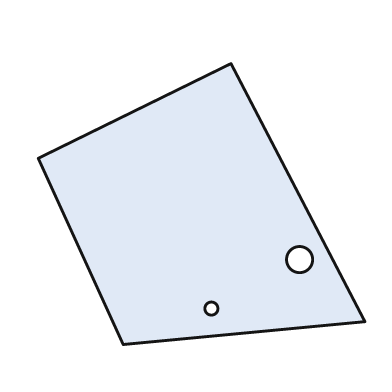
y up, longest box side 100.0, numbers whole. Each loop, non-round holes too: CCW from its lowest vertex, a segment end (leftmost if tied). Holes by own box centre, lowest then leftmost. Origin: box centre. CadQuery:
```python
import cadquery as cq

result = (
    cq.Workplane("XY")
    .moveTo(-24.0, -43.0)
    .lineTo(50.0, -36.0)
    .lineTo(9.0, 43.0)
    .lineTo(-50.0, 14.0)
    .close()
    .moveTo(3.0, -32.0)
    .circle(2.0)
    .moveTo(30.0, -17.0)
    .circle(4.0)
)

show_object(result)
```